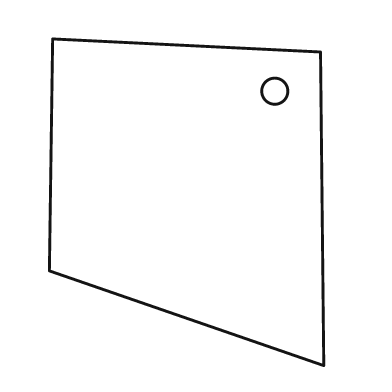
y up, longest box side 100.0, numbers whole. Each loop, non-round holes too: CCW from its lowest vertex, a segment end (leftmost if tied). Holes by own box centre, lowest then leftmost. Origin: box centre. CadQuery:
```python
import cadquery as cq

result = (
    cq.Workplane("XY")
    .moveTo(42.0, -50.0)
    .lineTo(41.0, 46.0)
    .lineTo(-41.0, 50.0)
    .lineTo(-42.0, -21.0)
    .close()
    .moveTo(27.0, 34.0)
    .circle(4.0)
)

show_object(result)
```